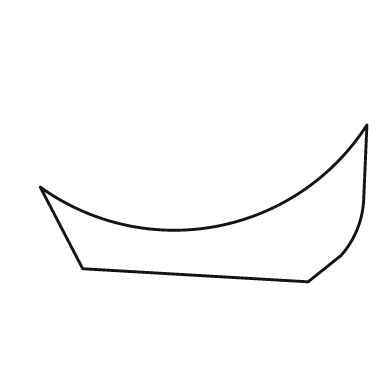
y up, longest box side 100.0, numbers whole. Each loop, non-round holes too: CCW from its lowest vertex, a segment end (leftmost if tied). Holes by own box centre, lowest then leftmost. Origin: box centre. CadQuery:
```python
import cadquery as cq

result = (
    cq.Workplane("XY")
    .moveTo(32.0, -24.0)
    .lineTo(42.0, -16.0)
    .threePointArc((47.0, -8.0), (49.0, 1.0))
    .lineTo(50.0, 24.0)
    .threePointArc((4.0, -7.0), (-50.0, 5.0))
    .lineTo(-37.0, -20.0)
    .close()
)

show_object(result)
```